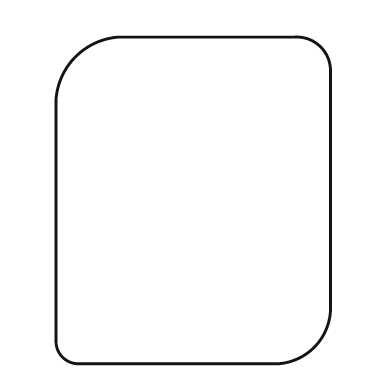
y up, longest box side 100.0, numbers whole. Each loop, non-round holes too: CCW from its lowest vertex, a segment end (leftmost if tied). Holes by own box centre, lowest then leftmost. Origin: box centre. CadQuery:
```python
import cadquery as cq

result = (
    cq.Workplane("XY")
    .moveTo(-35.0, -50.0)
    .lineTo(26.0, -50.0)
    .threePointArc((37.0, -45.0), (42.0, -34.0))
    .lineTo(42.0, 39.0)
    .threePointArc((39.0, 47.0), (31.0, 50.0))
    .lineTo(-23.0, 50.0)
    .threePointArc((-36.0, 44.0), (-42.0, 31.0))
    .lineTo(-42.0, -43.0)
    .threePointArc((-40.0, -48.0), (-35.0, -50.0))
    .close()
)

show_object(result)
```